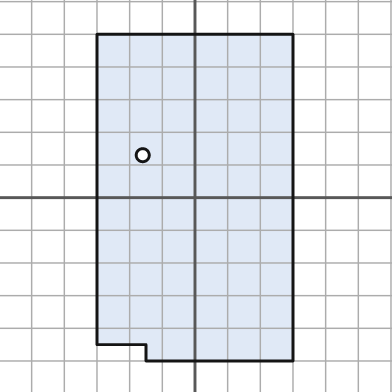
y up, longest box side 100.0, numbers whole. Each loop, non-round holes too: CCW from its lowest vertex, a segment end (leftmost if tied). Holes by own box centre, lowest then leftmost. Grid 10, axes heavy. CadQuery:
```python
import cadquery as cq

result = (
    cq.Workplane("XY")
    .moveTo(-15.0, -50.0)
    .lineTo(30.0, -50.0)
    .lineTo(30.0, 50.0)
    .lineTo(-30.0, 50.0)
    .lineTo(-30.0, -45.0)
    .lineTo(-15.0, -45.0)
    .close()
    .moveTo(-16.0, 13.0)
    .circle(2.0)
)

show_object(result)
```